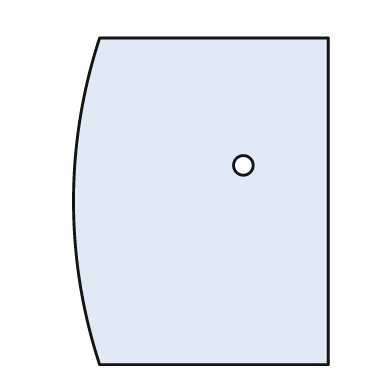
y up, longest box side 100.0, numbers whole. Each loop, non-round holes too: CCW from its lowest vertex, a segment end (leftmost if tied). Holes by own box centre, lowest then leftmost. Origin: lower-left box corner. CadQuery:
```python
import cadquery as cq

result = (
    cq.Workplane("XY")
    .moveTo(8.0, 0.0)
    .lineTo(78.0, 0.0)
    .lineTo(78.0, 100.0)
    .lineTo(8.0, 100.0)
    .threePointArc((0.0, 50.0), (8.0, 0.0))
    .close()
    .moveTo(52.0, 61.0)
    .circle(3.0)
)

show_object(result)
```